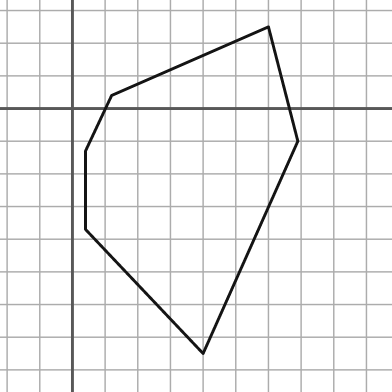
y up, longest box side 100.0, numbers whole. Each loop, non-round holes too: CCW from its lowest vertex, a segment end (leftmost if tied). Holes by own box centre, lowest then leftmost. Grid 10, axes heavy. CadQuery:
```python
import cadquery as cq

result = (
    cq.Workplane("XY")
    .moveTo(40.0, -75.0)
    .lineTo(69.0, -10.0)
    .lineTo(60.0, 25.0)
    .lineTo(12.0, 4.0)
    .lineTo(4.0, -13.0)
    .lineTo(4.0, -37.0)
    .close()
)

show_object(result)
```